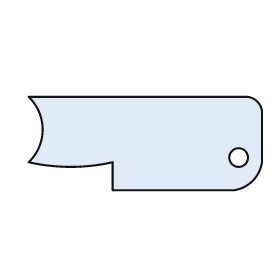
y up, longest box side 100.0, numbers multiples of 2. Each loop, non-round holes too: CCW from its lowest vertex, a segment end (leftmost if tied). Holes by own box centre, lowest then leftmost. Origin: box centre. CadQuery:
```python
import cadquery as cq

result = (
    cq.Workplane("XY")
    .moveTo(-14.0, -20.0)
    .lineTo(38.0, -20.0)
    .threePointArc((46.0, -16.0), (50.0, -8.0))
    .lineTo(50.0, 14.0)
    .threePointArc((48.0, 18.0), (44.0, 20.0))
    .lineTo(-50.0, 20.0)
    .threePointArc((-44.0, 6.0), (-50.0, -8.0))
    .threePointArc((-32.0, -10.0), (-14.0, -8.0))
    .close()
    .moveTo(40.0, -6.0)
    .circle(4.0)
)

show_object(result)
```